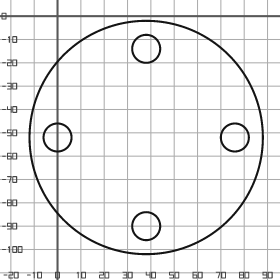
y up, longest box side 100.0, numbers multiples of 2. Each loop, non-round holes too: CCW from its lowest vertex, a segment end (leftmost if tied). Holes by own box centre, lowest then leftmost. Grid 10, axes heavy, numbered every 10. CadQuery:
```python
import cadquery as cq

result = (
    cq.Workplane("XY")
    .moveTo(38.0, -52.0)
    .circle(50.0)
    .moveTo(38.0, -90.0)
    .circle(6.0)
    .moveTo(0.0, -52.0)
    .circle(6.0)
    .moveTo(76.0, -52.0)
    .circle(6.0)
    .moveTo(38.0, -14.0)
    .circle(6.0)
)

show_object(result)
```